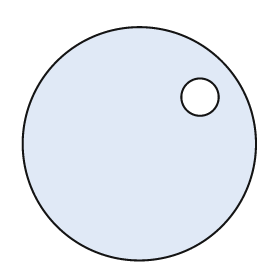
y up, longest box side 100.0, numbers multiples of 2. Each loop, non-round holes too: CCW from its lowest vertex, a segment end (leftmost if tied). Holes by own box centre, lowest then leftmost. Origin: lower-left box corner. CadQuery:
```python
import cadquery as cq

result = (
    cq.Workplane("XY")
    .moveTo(50.0, 50.0)
    .circle(50.0)
    .moveTo(76.0, 70.0)
    .circle(8.0)
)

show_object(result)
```